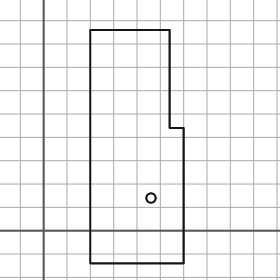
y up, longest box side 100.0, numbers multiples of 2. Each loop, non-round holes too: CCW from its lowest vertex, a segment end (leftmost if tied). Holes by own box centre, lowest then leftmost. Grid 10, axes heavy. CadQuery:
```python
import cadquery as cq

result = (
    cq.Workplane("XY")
    .moveTo(20.0, -14.0)
    .lineTo(60.0, -14.0)
    .lineTo(60.0, 44.0)
    .lineTo(54.0, 44.0)
    .lineTo(54.0, 86.0)
    .lineTo(20.0, 86.0)
    .close()
    .moveTo(46.0, 14.0)
    .circle(2.0)
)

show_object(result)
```